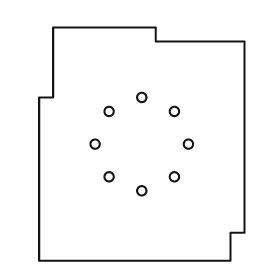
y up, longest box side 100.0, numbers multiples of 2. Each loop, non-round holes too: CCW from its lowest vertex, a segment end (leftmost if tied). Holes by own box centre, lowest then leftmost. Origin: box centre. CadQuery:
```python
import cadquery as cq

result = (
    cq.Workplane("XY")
    .moveTo(-44.0, -50.0)
    .lineTo(38.0, -50.0)
    .lineTo(38.0, -38.0)
    .lineTo(44.0, -38.0)
    .lineTo(44.0, 44.0)
    .lineTo(6.0, 44.0)
    .lineTo(6.0, 50.0)
    .lineTo(-38.0, 50.0)
    .lineTo(-38.0, 20.0)
    .lineTo(-44.0, 20.0)
    .close()
    .moveTo(0.0, -20.0)
    .circle(2.0)
    .moveTo(-14.0, -14.0)
    .circle(2.0)
    .moveTo(14.0, -14.0)
    .circle(2.0)
    .moveTo(-20.0, 0.0)
    .circle(2.0)
    .moveTo(20.0, 0.0)
    .circle(2.0)
    .moveTo(-14.0, 14.0)
    .circle(2.0)
    .moveTo(14.0, 14.0)
    .circle(2.0)
    .moveTo(0.0, 20.0)
    .circle(2.0)
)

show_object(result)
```